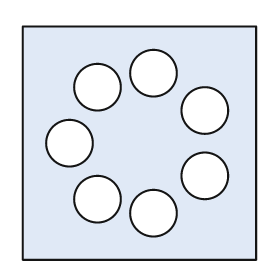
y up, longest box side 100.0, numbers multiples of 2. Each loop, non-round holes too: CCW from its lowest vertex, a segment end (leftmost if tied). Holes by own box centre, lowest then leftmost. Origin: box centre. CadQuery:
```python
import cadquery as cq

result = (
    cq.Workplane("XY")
    .moveTo(-50.0, -50.0)
    .lineTo(50.0, -50.0)
    .lineTo(50.0, 50.0)
    .lineTo(-50.0, 50.0)
    .close()
    .moveTo(6.0, -30.0)
    .circle(10.0)
    .moveTo(-18.0, -24.0)
    .circle(10.0)
    .moveTo(28.0, -14.0)
    .circle(10.0)
    .moveTo(-30.0, 0.0)
    .circle(10.0)
    .moveTo(28.0, 14.0)
    .circle(10.0)
    .moveTo(-18.0, 24.0)
    .circle(10.0)
    .moveTo(6.0, 30.0)
    .circle(10.0)
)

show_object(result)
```